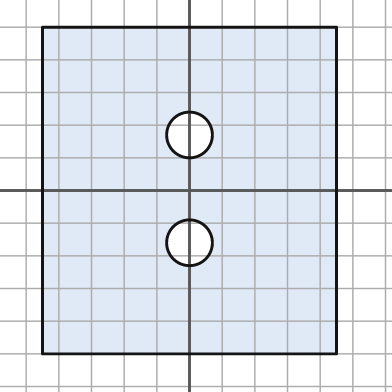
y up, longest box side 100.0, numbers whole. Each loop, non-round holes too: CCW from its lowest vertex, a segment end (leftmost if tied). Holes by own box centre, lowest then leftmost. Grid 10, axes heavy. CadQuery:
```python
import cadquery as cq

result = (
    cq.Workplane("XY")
    .moveTo(-45.0, -50.0)
    .lineTo(45.0, -50.0)
    .lineTo(45.0, 50.0)
    .lineTo(-45.0, 50.0)
    .close()
    .moveTo(0.0, -16.0)
    .circle(7.0)
    .moveTo(0.0, 17.0)
    .circle(7.0)
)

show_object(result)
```